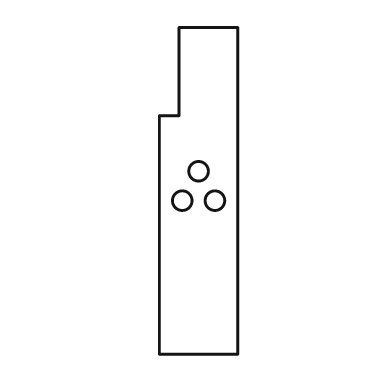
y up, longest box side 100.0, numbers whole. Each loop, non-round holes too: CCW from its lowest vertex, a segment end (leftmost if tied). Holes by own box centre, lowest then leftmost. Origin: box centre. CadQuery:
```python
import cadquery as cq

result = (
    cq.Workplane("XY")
    .moveTo(-12.0, -50.0)
    .lineTo(12.0, -50.0)
    .lineTo(12.0, 50.0)
    .lineTo(-6.0, 50.0)
    .lineTo(-6.0, 23.0)
    .lineTo(-12.0, 23.0)
    .close()
    .moveTo(-5.0, -3.0)
    .circle(3.0)
    .moveTo(5.0, -3.0)
    .circle(3.0)
    .moveTo(0.0, 6.0)
    .circle(3.0)
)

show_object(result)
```